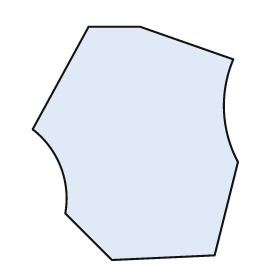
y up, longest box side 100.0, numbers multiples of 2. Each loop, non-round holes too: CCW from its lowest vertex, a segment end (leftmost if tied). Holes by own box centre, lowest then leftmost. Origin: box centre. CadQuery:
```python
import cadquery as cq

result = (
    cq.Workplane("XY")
    .moveTo(-10.0, -50.0)
    .lineTo(34.0, -48.0)
    .lineTo(44.0, -8.0)
    .threePointArc((38.0, 14.0), (42.0, 36.0))
    .lineTo(2.0, 50.0)
    .lineTo(-20.0, 50.0)
    .lineTo(-44.0, 6.0)
    .threePointArc((-32.0, -10.0), (-30.0, -30.0))
    .close()
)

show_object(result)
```